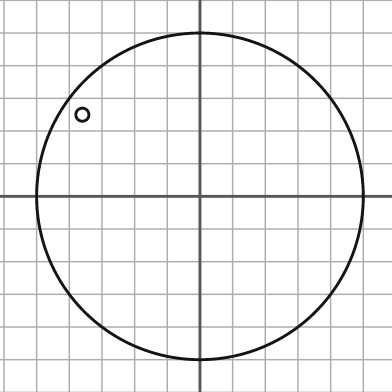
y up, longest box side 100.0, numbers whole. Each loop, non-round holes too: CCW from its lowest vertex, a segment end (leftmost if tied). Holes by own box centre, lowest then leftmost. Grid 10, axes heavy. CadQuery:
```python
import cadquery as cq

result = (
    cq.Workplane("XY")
    .moveTo(0.0, 0.0)
    .circle(50.0)
    .moveTo(-36.0, 25.0)
    .circle(2.0)
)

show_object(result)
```